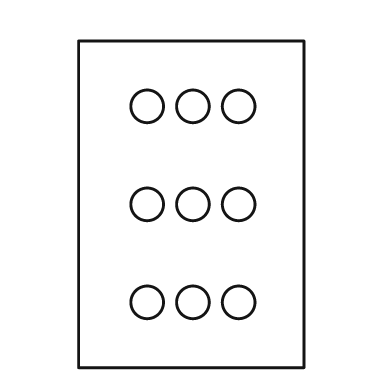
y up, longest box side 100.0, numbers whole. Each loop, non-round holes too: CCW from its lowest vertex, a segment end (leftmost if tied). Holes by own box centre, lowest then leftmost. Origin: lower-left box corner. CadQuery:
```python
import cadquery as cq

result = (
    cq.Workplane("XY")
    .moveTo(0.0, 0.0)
    .lineTo(69.0, 0.0)
    .lineTo(69.0, 100.0)
    .lineTo(0.0, 100.0)
    .close()
    .moveTo(21.0, 20.0)
    .circle(5.0)
    .moveTo(35.0, 20.0)
    .circle(5.0)
    .moveTo(49.0, 20.0)
    .circle(5.0)
    .moveTo(21.0, 50.0)
    .circle(5.0)
    .moveTo(35.0, 50.0)
    .circle(5.0)
    .moveTo(49.0, 50.0)
    .circle(5.0)
    .moveTo(21.0, 80.0)
    .circle(5.0)
    .moveTo(35.0, 80.0)
    .circle(5.0)
    .moveTo(49.0, 80.0)
    .circle(5.0)
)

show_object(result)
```